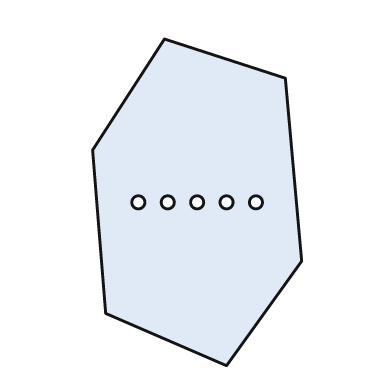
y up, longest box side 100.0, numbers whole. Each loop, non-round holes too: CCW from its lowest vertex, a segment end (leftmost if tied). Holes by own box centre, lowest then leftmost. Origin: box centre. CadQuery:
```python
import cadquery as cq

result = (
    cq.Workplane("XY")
    .moveTo(9.0, -50.0)
    .lineTo(32.0, -18.0)
    .lineTo(27.0, 38.0)
    .lineTo(-10.0, 50.0)
    .lineTo(-32.0, 16.0)
    .lineTo(-28.0, -34.0)
    .close()
    .moveTo(-18.0, 0.0)
    .circle(2.0)
    .moveTo(-9.0, 0.0)
    .circle(2.0)
    .moveTo(0.0, 0.0)
    .circle(2.0)
    .moveTo(9.0, 0.0)
    .circle(2.0)
    .moveTo(18.0, 0.0)
    .circle(2.0)
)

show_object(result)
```